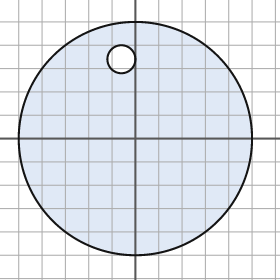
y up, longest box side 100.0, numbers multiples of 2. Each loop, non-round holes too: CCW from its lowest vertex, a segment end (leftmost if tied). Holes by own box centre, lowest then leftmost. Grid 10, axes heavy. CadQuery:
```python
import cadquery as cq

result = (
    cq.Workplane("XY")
    .moveTo(0.0, 0.0)
    .circle(50.0)
    .moveTo(-6.0, 34.0)
    .circle(6.0)
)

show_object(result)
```